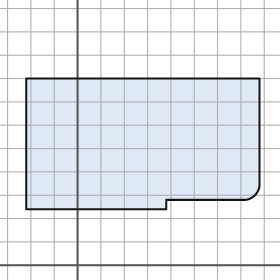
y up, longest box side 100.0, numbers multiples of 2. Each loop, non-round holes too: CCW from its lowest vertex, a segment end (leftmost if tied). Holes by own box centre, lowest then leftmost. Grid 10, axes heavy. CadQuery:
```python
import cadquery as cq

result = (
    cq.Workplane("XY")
    .moveTo(-22.0, 24.0)
    .lineTo(38.0, 24.0)
    .lineTo(38.0, 28.0)
    .lineTo(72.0, 28.0)
    .threePointArc((76.0, 30.0), (78.0, 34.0))
    .lineTo(78.0, 80.0)
    .lineTo(-22.0, 80.0)
    .close()
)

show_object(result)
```